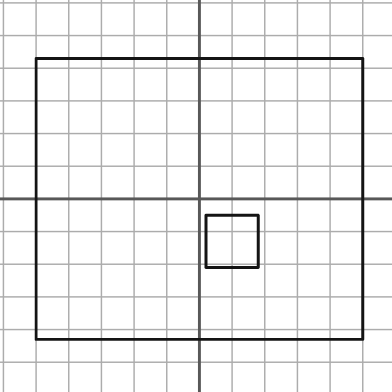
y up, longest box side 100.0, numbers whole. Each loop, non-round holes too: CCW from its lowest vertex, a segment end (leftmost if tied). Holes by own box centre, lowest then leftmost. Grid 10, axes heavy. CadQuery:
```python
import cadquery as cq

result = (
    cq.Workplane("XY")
    .moveTo(-50.0, -43.0)
    .lineTo(50.0, -43.0)
    .lineTo(50.0, 43.0)
    .lineTo(-50.0, 43.0)
    .close()
    .moveTo(2.0, -21.0)
    .lineTo(18.0, -21.0)
    .lineTo(18.0, -5.0)
    .lineTo(2.0, -5.0)
    .close()
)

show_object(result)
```